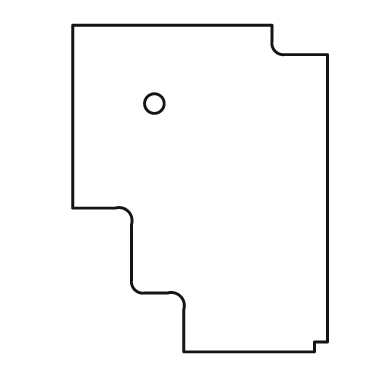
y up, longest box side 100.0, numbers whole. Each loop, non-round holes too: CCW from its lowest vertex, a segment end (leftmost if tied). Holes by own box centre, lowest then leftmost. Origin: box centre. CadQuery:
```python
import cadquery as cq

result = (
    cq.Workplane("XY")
    .moveTo(-5.0, -50.0)
    .lineTo(35.0, -50.0)
    .lineTo(35.0, -47.0)
    .lineTo(39.0, -47.0)
    .lineTo(39.0, 41.0)
    .lineTo(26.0, 41.0)
    .threePointArc((23.0, 42.0), (22.0, 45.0))
    .lineTo(22.0, 50.0)
    .lineTo(-39.0, 50.0)
    .lineTo(-39.0, -6.0)
    .lineTo(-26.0, -6.0)
    .threePointArc((-22.0, -7.0), (-21.0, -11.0))
    .lineTo(-21.0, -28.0)
    .threePointArc((-20.0, -31.0), (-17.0, -32.0))
    .lineTo(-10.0, -32.0)
    .threePointArc((-6.0, -33.0), (-5.0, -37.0))
    .close()
    .moveTo(-14.0, 26.0)
    .circle(3.0)
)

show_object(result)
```